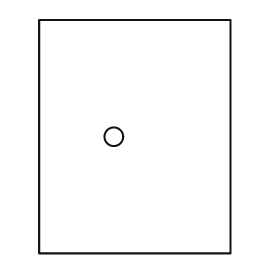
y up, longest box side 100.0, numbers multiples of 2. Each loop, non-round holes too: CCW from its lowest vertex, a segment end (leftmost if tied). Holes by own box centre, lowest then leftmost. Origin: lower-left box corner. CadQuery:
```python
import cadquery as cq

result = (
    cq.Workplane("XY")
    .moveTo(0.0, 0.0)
    .lineTo(82.0, 0.0)
    .lineTo(82.0, 100.0)
    .lineTo(0.0, 100.0)
    .close()
    .moveTo(32.0, 50.0)
    .circle(4.0)
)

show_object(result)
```